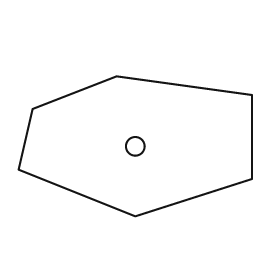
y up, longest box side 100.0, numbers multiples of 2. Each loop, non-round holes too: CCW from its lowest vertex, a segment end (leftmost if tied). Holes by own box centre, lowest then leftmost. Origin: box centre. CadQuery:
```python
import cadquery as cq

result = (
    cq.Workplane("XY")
    .moveTo(0.0, -30.0)
    .lineTo(50.0, -14.0)
    .lineTo(50.0, 22.0)
    .lineTo(-8.0, 30.0)
    .lineTo(-44.0, 16.0)
    .lineTo(-50.0, -10.0)
    .close()
    .moveTo(0.0, 0.0)
    .circle(4.0)
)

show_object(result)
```